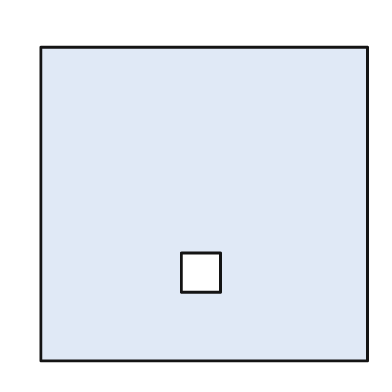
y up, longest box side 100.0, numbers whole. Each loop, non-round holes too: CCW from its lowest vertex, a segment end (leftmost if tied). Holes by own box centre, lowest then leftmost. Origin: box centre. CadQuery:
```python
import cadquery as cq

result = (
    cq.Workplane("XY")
    .moveTo(-50.0, -48.0)
    .lineTo(50.0, -48.0)
    .lineTo(50.0, 48.0)
    .lineTo(-50.0, 48.0)
    .close()
    .moveTo(-7.0, -27.0)
    .lineTo(5.0, -27.0)
    .lineTo(5.0, -15.0)
    .lineTo(-7.0, -15.0)
    .close()
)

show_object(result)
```